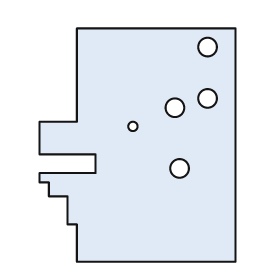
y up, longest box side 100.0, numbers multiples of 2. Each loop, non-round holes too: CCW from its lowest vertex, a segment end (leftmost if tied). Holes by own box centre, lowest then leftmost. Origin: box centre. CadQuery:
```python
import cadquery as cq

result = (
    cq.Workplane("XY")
    .moveTo(-26.0, -50.0)
    .lineTo(42.0, -50.0)
    .lineTo(42.0, 50.0)
    .lineTo(-26.0, 50.0)
    .lineTo(-26.0, 10.0)
    .lineTo(-42.0, 10.0)
    .lineTo(-42.0, -4.0)
    .lineTo(-18.0, -4.0)
    .lineTo(-18.0, -12.0)
    .lineTo(-42.0, -12.0)
    .lineTo(-42.0, -16.0)
    .lineTo(-38.0, -16.0)
    .lineTo(-38.0, -22.0)
    .lineTo(-30.0, -22.0)
    .lineTo(-30.0, -34.0)
    .lineTo(-26.0, -34.0)
    .close()
    .moveTo(18.0, -10.0)
    .circle(4.0)
    .moveTo(-2.0, 8.0)
    .circle(2.0)
    .moveTo(16.0, 16.0)
    .circle(4.0)
    .moveTo(30.0, 20.0)
    .circle(4.0)
    .moveTo(30.0, 42.0)
    .circle(4.0)
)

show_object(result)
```